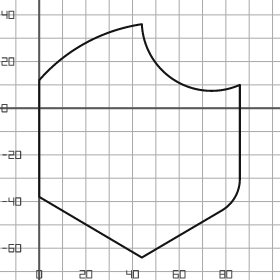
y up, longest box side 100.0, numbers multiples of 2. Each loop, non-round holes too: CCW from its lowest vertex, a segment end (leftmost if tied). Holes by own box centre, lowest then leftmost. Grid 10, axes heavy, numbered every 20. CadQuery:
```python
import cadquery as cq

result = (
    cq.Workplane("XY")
    .moveTo(44.0, -64.0)
    .lineTo(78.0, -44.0)
    .threePointArc((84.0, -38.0), (86.0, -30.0))
    .lineTo(86.0, 10.0)
    .threePointArc((58.0, 12.0), (44.0, 36.0))
    .threePointArc((20.0, 28.0), (0.0, 12.0))
    .lineTo(0.0, -38.0)
    .close()
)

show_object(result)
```